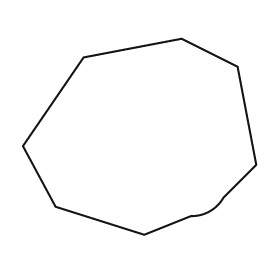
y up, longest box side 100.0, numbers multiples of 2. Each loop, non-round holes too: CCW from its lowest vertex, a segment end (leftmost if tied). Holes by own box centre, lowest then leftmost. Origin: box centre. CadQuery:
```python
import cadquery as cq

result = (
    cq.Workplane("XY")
    .moveTo(2.0, -42.0)
    .lineTo(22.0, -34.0)
    .threePointArc((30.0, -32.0), (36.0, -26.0))
    .lineTo(50.0, -12.0)
    .lineTo(42.0, 30.0)
    .lineTo(18.0, 42.0)
    .lineTo(-24.0, 34.0)
    .lineTo(-50.0, -4.0)
    .lineTo(-36.0, -30.0)
    .close()
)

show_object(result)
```